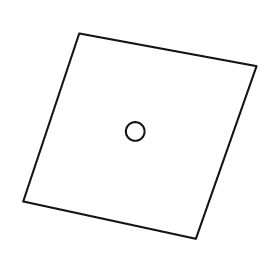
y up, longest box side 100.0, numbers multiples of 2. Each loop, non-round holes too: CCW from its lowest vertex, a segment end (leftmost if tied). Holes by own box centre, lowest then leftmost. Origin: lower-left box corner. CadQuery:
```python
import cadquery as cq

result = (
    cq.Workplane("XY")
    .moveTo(74.0, 0.0)
    .lineTo(100.0, 74.0)
    .lineTo(24.0, 88.0)
    .lineTo(0.0, 16.0)
    .close()
    .moveTo(48.0, 46.0)
    .circle(4.0)
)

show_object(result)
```